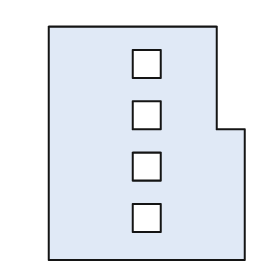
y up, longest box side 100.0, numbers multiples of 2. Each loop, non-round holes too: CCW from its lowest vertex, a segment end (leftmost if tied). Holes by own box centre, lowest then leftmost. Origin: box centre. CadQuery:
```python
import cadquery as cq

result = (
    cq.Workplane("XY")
    .moveTo(-42.0, -50.0)
    .lineTo(42.0, -50.0)
    .lineTo(42.0, 6.0)
    .lineTo(30.0, 6.0)
    .lineTo(30.0, 50.0)
    .lineTo(-42.0, 50.0)
    .close()
    .moveTo(-6.0, -38.0)
    .lineTo(6.0, -38.0)
    .lineTo(6.0, -26.0)
    .lineTo(-6.0, -26.0)
    .close()
    .moveTo(-6.0, -16.0)
    .lineTo(6.0, -16.0)
    .lineTo(6.0, -4.0)
    .lineTo(-6.0, -4.0)
    .close()
    .moveTo(-6.0, 6.0)
    .lineTo(6.0, 6.0)
    .lineTo(6.0, 18.0)
    .lineTo(-6.0, 18.0)
    .close()
    .moveTo(-6.0, 28.0)
    .lineTo(6.0, 28.0)
    .lineTo(6.0, 40.0)
    .lineTo(-6.0, 40.0)
    .close()
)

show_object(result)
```